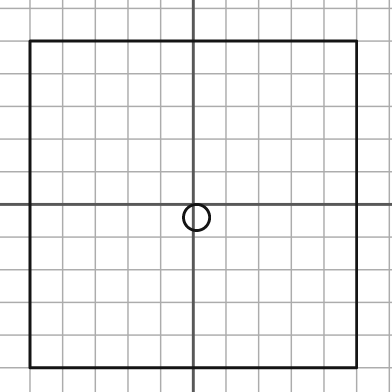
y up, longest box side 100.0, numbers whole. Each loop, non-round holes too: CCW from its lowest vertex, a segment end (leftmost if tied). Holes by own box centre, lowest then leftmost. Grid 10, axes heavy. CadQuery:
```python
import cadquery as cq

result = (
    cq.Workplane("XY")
    .moveTo(-50.0, -50.0)
    .lineTo(50.0, -50.0)
    .lineTo(50.0, 50.0)
    .lineTo(-50.0, 50.0)
    .close()
    .moveTo(1.0, -4.0)
    .circle(4.0)
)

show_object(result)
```